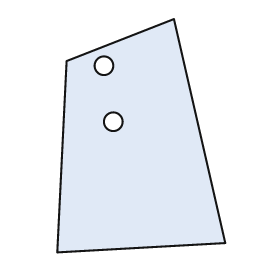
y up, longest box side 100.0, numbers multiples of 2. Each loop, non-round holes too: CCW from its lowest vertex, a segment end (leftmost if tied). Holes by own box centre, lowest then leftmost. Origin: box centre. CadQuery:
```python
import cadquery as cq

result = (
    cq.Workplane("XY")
    .moveTo(-36.0, -50.0)
    .lineTo(36.0, -46.0)
    .lineTo(14.0, 50.0)
    .lineTo(-32.0, 32.0)
    .close()
    .moveTo(-12.0, 6.0)
    .circle(4.0)
    .moveTo(-16.0, 30.0)
    .circle(4.0)
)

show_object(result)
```